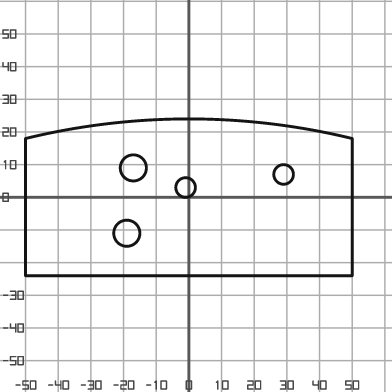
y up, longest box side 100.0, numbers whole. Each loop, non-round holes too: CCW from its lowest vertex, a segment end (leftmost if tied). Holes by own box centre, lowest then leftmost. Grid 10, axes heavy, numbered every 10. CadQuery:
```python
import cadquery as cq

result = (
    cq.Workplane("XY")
    .moveTo(-50.0, -24.0)
    .lineTo(50.0, -24.0)
    .lineTo(50.0, 18.0)
    .threePointArc((0.0, 24.0), (-50.0, 18.0))
    .close()
    .moveTo(-19.0, -11.0)
    .circle(4.0)
    .moveTo(-1.0, 3.0)
    .circle(3.0)
    .moveTo(29.0, 7.0)
    .circle(3.0)
    .moveTo(-17.0, 9.0)
    .circle(4.0)
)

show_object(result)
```